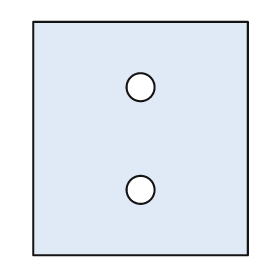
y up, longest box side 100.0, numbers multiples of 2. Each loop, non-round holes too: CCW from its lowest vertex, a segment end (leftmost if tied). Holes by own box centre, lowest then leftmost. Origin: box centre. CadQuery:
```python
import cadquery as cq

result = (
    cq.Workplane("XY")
    .moveTo(-46.0, -50.0)
    .lineTo(46.0, -50.0)
    .lineTo(46.0, 50.0)
    .lineTo(-46.0, 50.0)
    .close()
    .moveTo(0.0, -22.0)
    .circle(6.0)
    .moveTo(0.0, 22.0)
    .circle(6.0)
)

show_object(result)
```